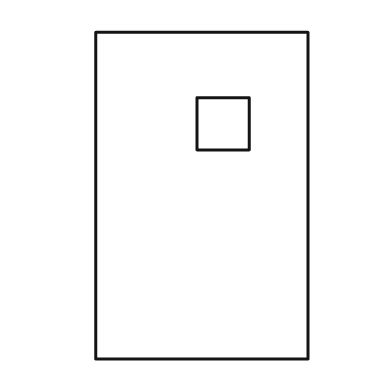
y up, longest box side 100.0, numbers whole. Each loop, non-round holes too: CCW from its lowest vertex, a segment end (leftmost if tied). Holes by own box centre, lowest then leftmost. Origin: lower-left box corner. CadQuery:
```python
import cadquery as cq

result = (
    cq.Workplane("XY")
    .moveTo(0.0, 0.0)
    .lineTo(65.0, 0.0)
    .lineTo(65.0, 100.0)
    .lineTo(0.0, 100.0)
    .close()
    .moveTo(31.0, 64.0)
    .lineTo(47.0, 64.0)
    .lineTo(47.0, 80.0)
    .lineTo(31.0, 80.0)
    .close()
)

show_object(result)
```